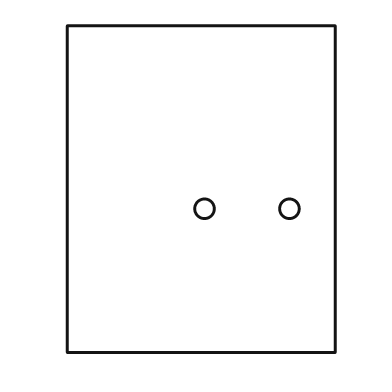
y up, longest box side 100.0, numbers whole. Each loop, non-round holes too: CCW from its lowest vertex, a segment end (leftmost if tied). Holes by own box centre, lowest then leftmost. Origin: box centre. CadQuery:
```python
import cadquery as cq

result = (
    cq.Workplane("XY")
    .moveTo(-41.0, -50.0)
    .lineTo(41.0, -50.0)
    .lineTo(41.0, 50.0)
    .lineTo(-41.0, 50.0)
    .close()
    .moveTo(1.0, -6.0)
    .circle(3.0)
    .moveTo(27.0, -6.0)
    .circle(3.0)
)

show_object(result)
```